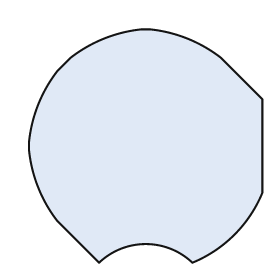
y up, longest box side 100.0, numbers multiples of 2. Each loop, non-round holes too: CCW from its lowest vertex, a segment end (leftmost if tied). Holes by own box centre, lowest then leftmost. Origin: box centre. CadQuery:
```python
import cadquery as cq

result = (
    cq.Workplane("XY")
    .moveTo(-20.0, -50.0)
    .threePointArc((0.0, -42.0), (20.0, -50.0))
    .threePointArc((38.0, -38.0), (50.0, -20.0))
    .lineTo(50.0, 20.0)
    .lineTo(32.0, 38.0)
    .threePointArc((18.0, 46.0), (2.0, 50.0))
    .lineTo(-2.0, 50.0)
    .threePointArc((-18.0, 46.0), (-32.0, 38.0))
    .lineTo(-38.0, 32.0)
    .threePointArc((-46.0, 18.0), (-50.0, 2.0))
    .lineTo(-50.0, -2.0)
    .threePointArc((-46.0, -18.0), (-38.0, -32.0))
    .close()
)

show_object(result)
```